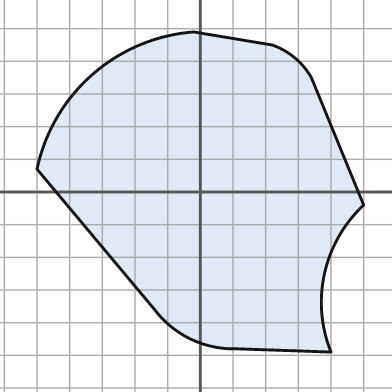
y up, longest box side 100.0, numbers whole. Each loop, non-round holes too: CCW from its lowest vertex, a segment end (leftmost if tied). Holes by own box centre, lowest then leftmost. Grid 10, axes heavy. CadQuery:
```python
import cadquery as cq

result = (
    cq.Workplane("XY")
    .moveTo(40.0, -49.0)
    .threePointArc((38.0, -25.0), (50.0, -4.0))
    .lineTo(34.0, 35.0)
    .threePointArc((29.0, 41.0), (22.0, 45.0))
    .lineTo(-2.0, 49.0)
    .threePointArc((-33.0, 36.0), (-50.0, 7.0))
    .lineTo(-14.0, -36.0)
    .threePointArc((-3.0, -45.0), (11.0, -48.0))
    .close()
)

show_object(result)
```